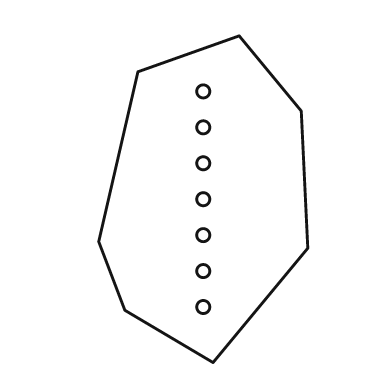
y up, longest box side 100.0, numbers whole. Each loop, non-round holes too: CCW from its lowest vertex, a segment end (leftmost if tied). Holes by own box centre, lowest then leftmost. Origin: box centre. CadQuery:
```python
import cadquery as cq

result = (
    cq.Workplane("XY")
    .moveTo(3.0, -50.0)
    .lineTo(32.0, -15.0)
    .lineTo(30.0, 27.0)
    .lineTo(11.0, 50.0)
    .lineTo(-20.0, 39.0)
    .lineTo(-32.0, -13.0)
    .lineTo(-24.0, -34.0)
    .close()
    .moveTo(0.0, -33.0)
    .circle(2.0)
    .moveTo(0.0, -22.0)
    .circle(2.0)
    .moveTo(0.0, -11.0)
    .circle(2.0)
    .moveTo(0.0, 0.0)
    .circle(2.0)
    .moveTo(0.0, 11.0)
    .circle(2.0)
    .moveTo(0.0, 22.0)
    .circle(2.0)
    .moveTo(0.0, 33.0)
    .circle(2.0)
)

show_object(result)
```